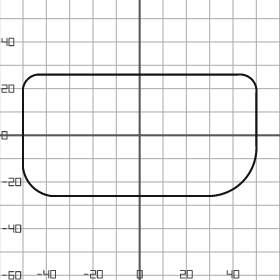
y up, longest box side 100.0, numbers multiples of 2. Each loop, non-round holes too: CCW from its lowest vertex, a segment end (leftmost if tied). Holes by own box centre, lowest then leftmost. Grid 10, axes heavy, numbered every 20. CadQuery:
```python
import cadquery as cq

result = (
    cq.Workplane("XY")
    .moveTo(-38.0, -26.0)
    .lineTo(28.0, -26.0)
    .threePointArc((44.0, -20.0), (50.0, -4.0))
    .lineTo(50.0, 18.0)
    .threePointArc((48.0, 24.0), (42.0, 26.0))
    .lineTo(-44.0, 26.0)
    .threePointArc((-48.0, 24.0), (-50.0, 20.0))
    .lineTo(-50.0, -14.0)
    .threePointArc((-46.0, -22.0), (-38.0, -26.0))
    .close()
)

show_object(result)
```